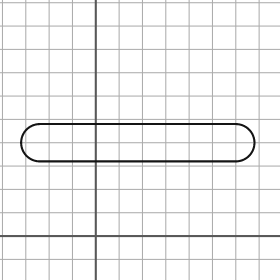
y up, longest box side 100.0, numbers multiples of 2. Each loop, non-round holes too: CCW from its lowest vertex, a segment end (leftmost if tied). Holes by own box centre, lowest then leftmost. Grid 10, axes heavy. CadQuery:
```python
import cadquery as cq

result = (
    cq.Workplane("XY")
    .moveTo(-24.0, 32.0)
    .lineTo(60.0, 32.0)
    .threePointArc((68.0, 40.0), (60.0, 48.0))
    .lineTo(-24.0, 48.0)
    .threePointArc((-32.0, 40.0), (-24.0, 32.0))
    .close()
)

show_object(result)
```